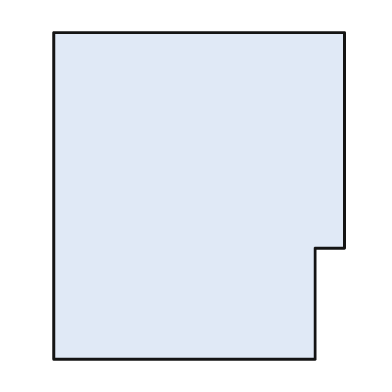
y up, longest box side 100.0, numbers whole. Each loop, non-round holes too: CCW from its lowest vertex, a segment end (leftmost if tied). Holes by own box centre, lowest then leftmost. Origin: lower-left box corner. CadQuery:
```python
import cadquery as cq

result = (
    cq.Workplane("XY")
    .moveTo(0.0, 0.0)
    .lineTo(80.0, 0.0)
    .lineTo(80.0, 34.0)
    .lineTo(89.0, 34.0)
    .lineTo(89.0, 100.0)
    .lineTo(0.0, 100.0)
    .close()
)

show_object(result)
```